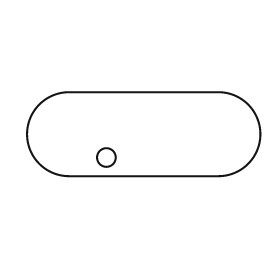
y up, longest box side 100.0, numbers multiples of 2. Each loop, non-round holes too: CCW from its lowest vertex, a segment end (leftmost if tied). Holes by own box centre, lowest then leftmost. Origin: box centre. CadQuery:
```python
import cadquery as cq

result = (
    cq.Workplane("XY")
    .moveTo(-32.0, -18.0)
    .lineTo(32.0, -18.0)
    .threePointArc((50.0, 0.0), (32.0, 18.0))
    .lineTo(-32.0, 18.0)
    .threePointArc((-50.0, 0.0), (-32.0, -18.0))
    .close()
    .moveTo(-16.0, -10.0)
    .circle(4.0)
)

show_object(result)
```